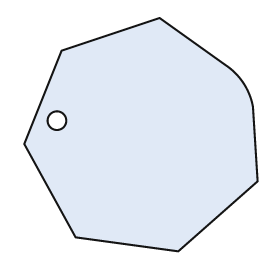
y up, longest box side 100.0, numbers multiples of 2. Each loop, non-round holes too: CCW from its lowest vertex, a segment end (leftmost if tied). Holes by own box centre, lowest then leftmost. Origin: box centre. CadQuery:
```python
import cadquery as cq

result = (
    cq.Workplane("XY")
    .moveTo(16.0, -50.0)
    .lineTo(50.0, -20.0)
    .lineTo(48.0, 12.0)
    .threePointArc((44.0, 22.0), (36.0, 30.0))
    .lineTo(8.0, 50.0)
    .lineTo(-34.0, 36.0)
    .lineTo(-50.0, -4.0)
    .lineTo(-28.0, -44.0)
    .close()
    .moveTo(-36.0, 6.0)
    .circle(4.0)
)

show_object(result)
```